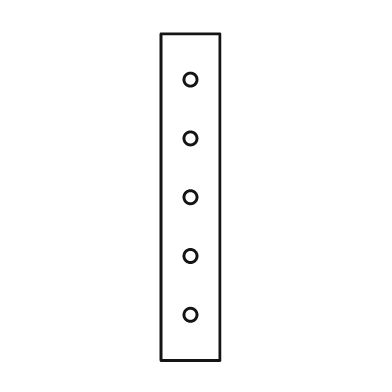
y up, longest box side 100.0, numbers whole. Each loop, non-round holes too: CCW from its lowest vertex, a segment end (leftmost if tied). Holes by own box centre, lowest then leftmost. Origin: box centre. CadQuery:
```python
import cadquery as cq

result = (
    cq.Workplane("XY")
    .moveTo(-9.0, -50.0)
    .lineTo(9.0, -50.0)
    .lineTo(9.0, 50.0)
    .lineTo(-9.0, 50.0)
    .close()
    .moveTo(0.0, -36.0)
    .circle(2.0)
    .moveTo(0.0, -18.0)
    .circle(2.0)
    .moveTo(0.0, 0.0)
    .circle(2.0)
    .moveTo(0.0, 18.0)
    .circle(2.0)
    .moveTo(0.0, 36.0)
    .circle(2.0)
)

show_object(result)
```